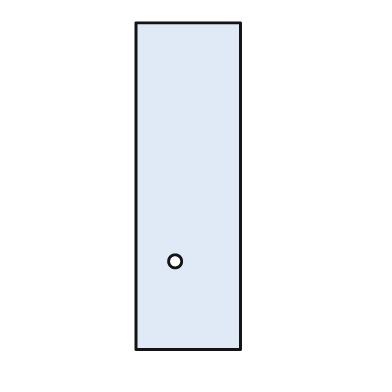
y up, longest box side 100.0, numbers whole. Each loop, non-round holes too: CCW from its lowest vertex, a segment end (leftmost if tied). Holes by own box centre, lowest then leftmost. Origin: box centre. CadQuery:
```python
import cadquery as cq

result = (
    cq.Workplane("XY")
    .moveTo(-16.0, -50.0)
    .lineTo(16.0, -50.0)
    .lineTo(16.0, 50.0)
    .lineTo(-16.0, 50.0)
    .close()
    .moveTo(-4.0, -23.0)
    .circle(2.0)
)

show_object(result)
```